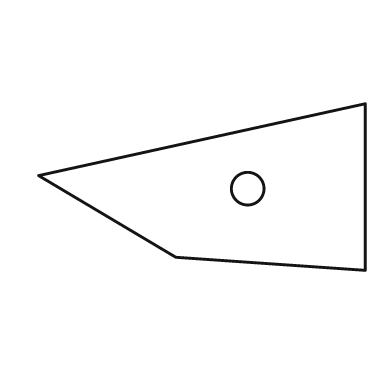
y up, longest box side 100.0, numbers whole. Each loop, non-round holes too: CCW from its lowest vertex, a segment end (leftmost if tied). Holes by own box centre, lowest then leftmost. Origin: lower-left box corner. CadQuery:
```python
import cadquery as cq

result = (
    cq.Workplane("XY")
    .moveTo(100.0, 0.0)
    .lineTo(100.0, 51.0)
    .lineTo(0.0, 29.0)
    .lineTo(42.0, 4.0)
    .close()
    .moveTo(64.0, 25.0)
    .circle(5.0)
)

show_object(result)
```